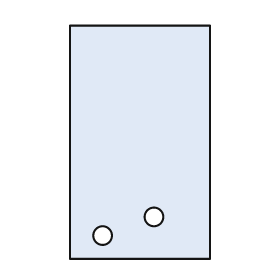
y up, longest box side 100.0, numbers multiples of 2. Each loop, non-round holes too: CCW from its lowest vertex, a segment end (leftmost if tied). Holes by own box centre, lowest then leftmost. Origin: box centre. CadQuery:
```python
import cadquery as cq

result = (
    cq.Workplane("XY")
    .moveTo(-30.0, -50.0)
    .lineTo(30.0, -50.0)
    .lineTo(30.0, 50.0)
    .lineTo(-30.0, 50.0)
    .close()
    .moveTo(-16.0, -40.0)
    .circle(4.0)
    .moveTo(6.0, -32.0)
    .circle(4.0)
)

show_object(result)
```